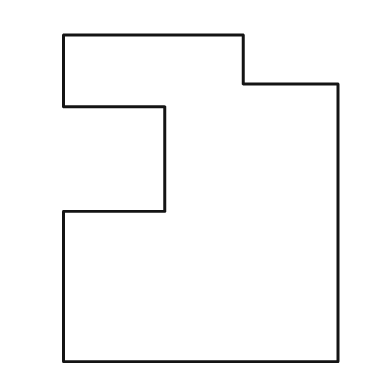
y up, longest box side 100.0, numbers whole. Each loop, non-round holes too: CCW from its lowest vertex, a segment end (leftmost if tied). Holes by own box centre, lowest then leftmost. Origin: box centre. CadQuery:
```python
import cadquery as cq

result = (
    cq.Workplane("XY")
    .moveTo(-42.0, -50.0)
    .lineTo(42.0, -50.0)
    .lineTo(42.0, 35.0)
    .lineTo(13.0, 35.0)
    .lineTo(13.0, 50.0)
    .lineTo(-42.0, 50.0)
    .lineTo(-42.0, 28.0)
    .lineTo(-11.0, 28.0)
    .lineTo(-11.0, -4.0)
    .lineTo(-42.0, -4.0)
    .close()
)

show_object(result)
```